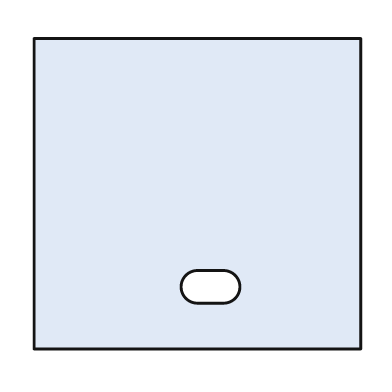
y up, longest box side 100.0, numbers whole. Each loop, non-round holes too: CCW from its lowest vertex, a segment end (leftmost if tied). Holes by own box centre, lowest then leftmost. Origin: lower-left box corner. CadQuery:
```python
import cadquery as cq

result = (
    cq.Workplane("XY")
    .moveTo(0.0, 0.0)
    .lineTo(100.0, 0.0)
    .lineTo(100.0, 95.0)
    .lineTo(0.0, 95.0)
    .close()
    .moveTo(50.0, 14.0)
    .lineTo(58.0, 14.0)
    .threePointArc((63.0, 19.0), (58.0, 24.0))
    .lineTo(50.0, 24.0)
    .threePointArc((45.0, 19.0), (50.0, 14.0))
    .close()
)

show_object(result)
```